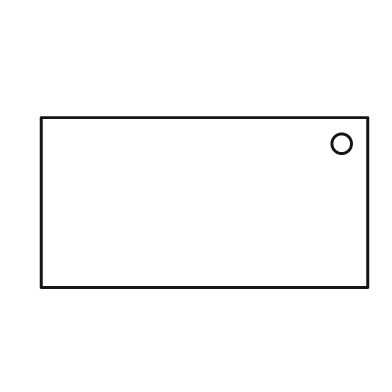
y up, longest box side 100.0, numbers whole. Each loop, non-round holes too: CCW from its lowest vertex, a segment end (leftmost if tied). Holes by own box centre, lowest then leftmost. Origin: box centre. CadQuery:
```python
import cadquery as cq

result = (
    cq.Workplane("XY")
    .moveTo(-50.0, -26.0)
    .lineTo(50.0, -26.0)
    .lineTo(50.0, 26.0)
    .lineTo(-50.0, 26.0)
    .close()
    .moveTo(42.0, 18.0)
    .circle(3.0)
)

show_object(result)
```